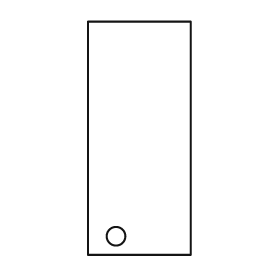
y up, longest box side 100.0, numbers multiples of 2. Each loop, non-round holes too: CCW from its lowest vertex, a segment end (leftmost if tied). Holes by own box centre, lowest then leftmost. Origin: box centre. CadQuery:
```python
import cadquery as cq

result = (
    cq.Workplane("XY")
    .moveTo(-22.0, -50.0)
    .lineTo(22.0, -50.0)
    .lineTo(22.0, 50.0)
    .lineTo(-22.0, 50.0)
    .close()
    .moveTo(-10.0, -42.0)
    .circle(4.0)
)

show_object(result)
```